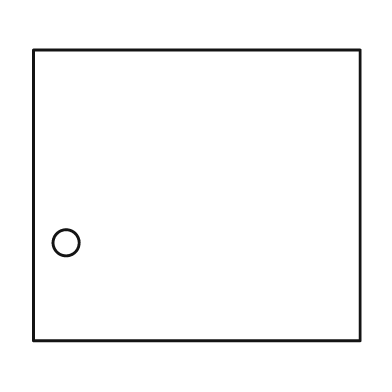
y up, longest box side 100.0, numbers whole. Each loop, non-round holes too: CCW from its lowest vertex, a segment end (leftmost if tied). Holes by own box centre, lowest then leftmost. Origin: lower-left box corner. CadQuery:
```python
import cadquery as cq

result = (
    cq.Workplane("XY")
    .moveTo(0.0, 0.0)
    .lineTo(100.0, 0.0)
    .lineTo(100.0, 89.0)
    .lineTo(0.0, 89.0)
    .close()
    .moveTo(10.0, 30.0)
    .circle(4.0)
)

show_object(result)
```